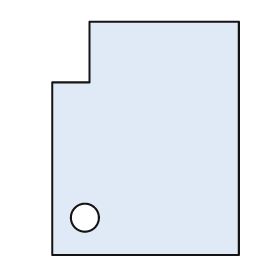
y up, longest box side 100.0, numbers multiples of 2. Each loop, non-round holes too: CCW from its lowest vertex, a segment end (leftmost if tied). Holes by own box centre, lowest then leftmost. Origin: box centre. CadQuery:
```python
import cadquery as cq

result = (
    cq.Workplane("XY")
    .moveTo(-40.0, -50.0)
    .lineTo(40.0, -50.0)
    .lineTo(40.0, 50.0)
    .lineTo(-24.0, 50.0)
    .lineTo(-24.0, 24.0)
    .lineTo(-40.0, 24.0)
    .close()
    .moveTo(-26.0, -34.0)
    .circle(6.0)
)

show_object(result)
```